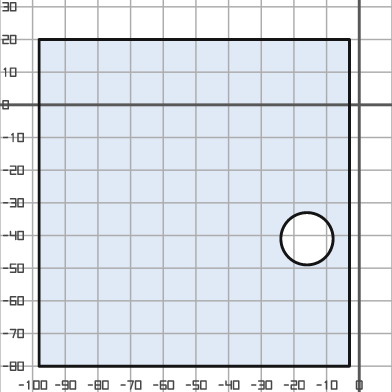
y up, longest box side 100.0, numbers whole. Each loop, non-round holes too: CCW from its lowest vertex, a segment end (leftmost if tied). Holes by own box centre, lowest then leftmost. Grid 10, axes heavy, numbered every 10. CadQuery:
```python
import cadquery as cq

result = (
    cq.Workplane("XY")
    .moveTo(-98.0, -80.0)
    .lineTo(-3.0, -80.0)
    .lineTo(-3.0, 20.0)
    .lineTo(-98.0, 20.0)
    .close()
    .moveTo(-16.0, -41.0)
    .circle(8.0)
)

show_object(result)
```